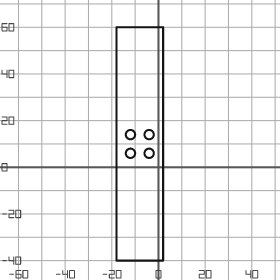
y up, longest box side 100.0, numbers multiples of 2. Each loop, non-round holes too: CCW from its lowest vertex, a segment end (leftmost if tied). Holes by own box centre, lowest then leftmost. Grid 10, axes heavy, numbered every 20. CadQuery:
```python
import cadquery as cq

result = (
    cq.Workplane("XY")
    .moveTo(-18.0, -40.0)
    .lineTo(2.0, -40.0)
    .lineTo(2.0, 60.0)
    .lineTo(-18.0, 60.0)
    .close()
    .moveTo(-12.0, 6.0)
    .circle(2.0)
    .moveTo(-4.0, 6.0)
    .circle(2.0)
    .moveTo(-12.0, 14.0)
    .circle(2.0)
    .moveTo(-4.0, 14.0)
    .circle(2.0)
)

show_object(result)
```